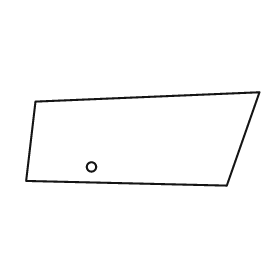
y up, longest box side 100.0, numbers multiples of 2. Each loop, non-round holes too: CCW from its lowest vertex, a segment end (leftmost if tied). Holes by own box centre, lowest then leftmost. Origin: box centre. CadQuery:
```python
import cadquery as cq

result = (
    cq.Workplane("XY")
    .moveTo(36.0, -20.0)
    .lineTo(50.0, 20.0)
    .lineTo(-46.0, 16.0)
    .lineTo(-50.0, -18.0)
    .close()
    .moveTo(-22.0, -12.0)
    .circle(2.0)
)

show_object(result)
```